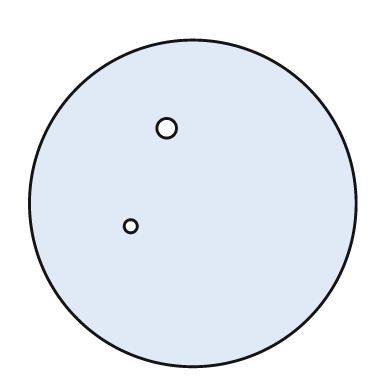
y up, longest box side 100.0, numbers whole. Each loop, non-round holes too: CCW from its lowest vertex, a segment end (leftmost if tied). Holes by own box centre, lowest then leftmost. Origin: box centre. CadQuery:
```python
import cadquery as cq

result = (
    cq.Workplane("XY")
    .moveTo(0.0, 0.0)
    .circle(50.0)
    .moveTo(-19.0, -7.0)
    .circle(2.0)
    .moveTo(-8.0, 23.0)
    .circle(3.0)
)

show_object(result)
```